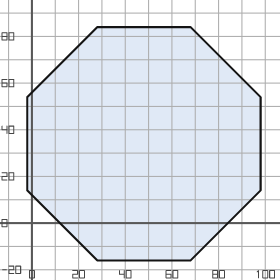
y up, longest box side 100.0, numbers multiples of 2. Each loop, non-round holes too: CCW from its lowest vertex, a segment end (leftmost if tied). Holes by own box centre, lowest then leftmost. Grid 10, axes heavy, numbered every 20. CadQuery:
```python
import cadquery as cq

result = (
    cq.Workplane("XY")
    .moveTo(28.0, -16.0)
    .lineTo(68.0, -16.0)
    .lineTo(98.0, 14.0)
    .lineTo(98.0, 54.0)
    .lineTo(68.0, 84.0)
    .lineTo(28.0, 84.0)
    .lineTo(-2.0, 54.0)
    .lineTo(-2.0, 14.0)
    .close()
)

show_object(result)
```